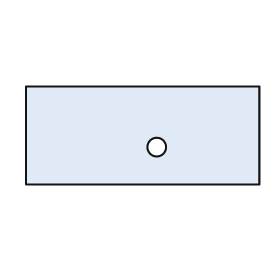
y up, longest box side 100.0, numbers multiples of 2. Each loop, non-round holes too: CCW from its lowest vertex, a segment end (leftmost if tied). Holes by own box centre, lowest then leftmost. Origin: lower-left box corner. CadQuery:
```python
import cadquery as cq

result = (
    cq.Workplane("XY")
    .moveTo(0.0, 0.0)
    .lineTo(100.0, 0.0)
    .lineTo(100.0, 42.0)
    .lineTo(0.0, 42.0)
    .close()
    .moveTo(56.0, 16.0)
    .circle(4.0)
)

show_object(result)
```